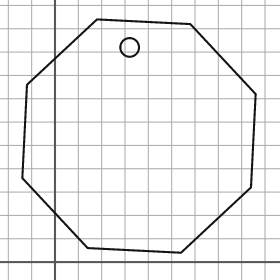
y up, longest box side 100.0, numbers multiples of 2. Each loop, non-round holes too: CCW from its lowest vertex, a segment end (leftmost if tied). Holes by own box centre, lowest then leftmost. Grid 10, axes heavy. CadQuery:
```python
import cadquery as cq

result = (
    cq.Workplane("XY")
    .moveTo(54.0, 4.0)
    .lineTo(84.0, 32.0)
    .lineTo(86.0, 72.0)
    .lineTo(58.0, 102.0)
    .lineTo(18.0, 104.0)
    .lineTo(-12.0, 76.0)
    .lineTo(-14.0, 36.0)
    .lineTo(14.0, 6.0)
    .close()
    .moveTo(32.0, 92.0)
    .circle(4.0)
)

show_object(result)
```